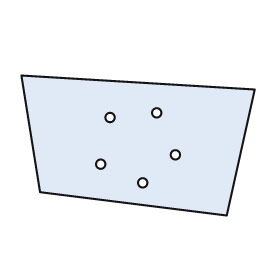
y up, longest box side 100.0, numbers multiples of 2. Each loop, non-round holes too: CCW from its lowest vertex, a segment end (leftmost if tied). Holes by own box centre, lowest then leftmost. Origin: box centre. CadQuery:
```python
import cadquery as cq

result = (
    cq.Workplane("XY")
    .moveTo(38.0, -30.0)
    .lineTo(50.0, 24.0)
    .lineTo(-50.0, 30.0)
    .lineTo(-42.0, -20.0)
    .close()
    .moveTo(2.0, -16.0)
    .circle(2.0)
    .moveTo(-16.0, -8.0)
    .circle(2.0)
    .moveTo(16.0, -4.0)
    .circle(2.0)
    .moveTo(-12.0, 12.0)
    .circle(2.0)
    .moveTo(8.0, 14.0)
    .circle(2.0)
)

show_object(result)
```